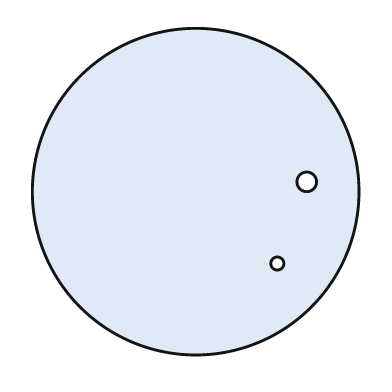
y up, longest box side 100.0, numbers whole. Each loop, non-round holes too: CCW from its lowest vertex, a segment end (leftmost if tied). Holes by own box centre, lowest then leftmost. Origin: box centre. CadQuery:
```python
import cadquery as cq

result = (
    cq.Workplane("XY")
    .moveTo(0.0, 0.0)
    .circle(50.0)
    .moveTo(25.0, -22.0)
    .circle(2.0)
    .moveTo(34.0, 3.0)
    .circle(3.0)
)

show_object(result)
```